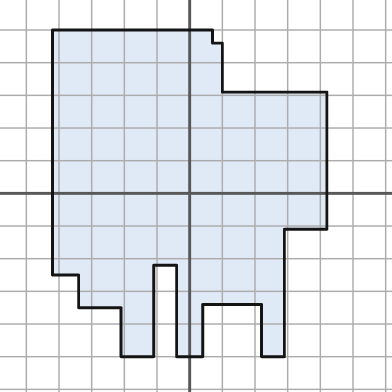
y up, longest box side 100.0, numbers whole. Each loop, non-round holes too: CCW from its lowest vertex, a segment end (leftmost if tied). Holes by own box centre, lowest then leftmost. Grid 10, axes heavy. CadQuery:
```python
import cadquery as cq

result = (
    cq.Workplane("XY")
    .moveTo(-21.0, -50.0)
    .lineTo(-11.0, -50.0)
    .lineTo(-11.0, -22.0)
    .lineTo(-4.0, -22.0)
    .lineTo(-4.0, -50.0)
    .lineTo(4.0, -50.0)
    .lineTo(4.0, -34.0)
    .lineTo(22.0, -34.0)
    .lineTo(22.0, -50.0)
    .lineTo(29.0, -50.0)
    .lineTo(29.0, -11.0)
    .lineTo(42.0, -11.0)
    .lineTo(42.0, 31.0)
    .lineTo(10.0, 31.0)
    .lineTo(10.0, 46.0)
    .lineTo(7.0, 46.0)
    .lineTo(7.0, 50.0)
    .lineTo(-42.0, 50.0)
    .lineTo(-42.0, -25.0)
    .lineTo(-34.0, -25.0)
    .lineTo(-34.0, -35.0)
    .lineTo(-21.0, -35.0)
    .close()
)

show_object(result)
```